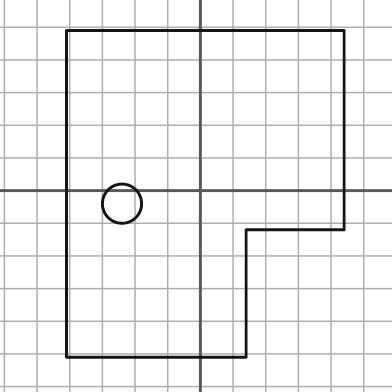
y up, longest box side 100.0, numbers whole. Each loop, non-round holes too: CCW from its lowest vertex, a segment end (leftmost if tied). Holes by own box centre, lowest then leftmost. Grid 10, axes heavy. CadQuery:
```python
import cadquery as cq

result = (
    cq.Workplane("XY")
    .moveTo(-41.0, -51.0)
    .lineTo(14.0, -51.0)
    .lineTo(14.0, -12.0)
    .lineTo(44.0, -12.0)
    .lineTo(44.0, 49.0)
    .lineTo(-41.0, 49.0)
    .close()
    .moveTo(-24.0, -4.0)
    .circle(6.0)
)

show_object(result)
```